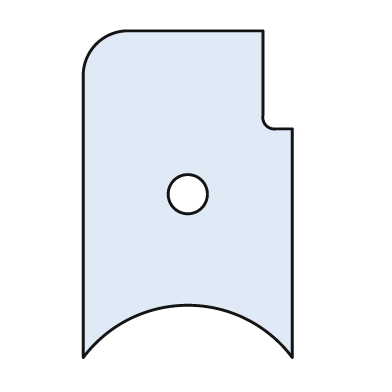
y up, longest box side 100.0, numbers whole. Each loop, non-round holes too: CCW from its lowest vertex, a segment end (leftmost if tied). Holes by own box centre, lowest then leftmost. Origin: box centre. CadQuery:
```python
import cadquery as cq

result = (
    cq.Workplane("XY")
    .moveTo(-32.0, -50.0)
    .threePointArc((0.0, -34.0), (32.0, -50.0))
    .lineTo(32.0, 20.0)
    .lineTo(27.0, 20.0)
    .threePointArc((24.0, 21.0), (23.0, 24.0))
    .lineTo(23.0, 50.0)
    .lineTo(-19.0, 50.0)
    .threePointArc((-28.0, 46.0), (-32.0, 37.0))
    .close()
    .moveTo(0.0, 0.0)
    .circle(6.0)
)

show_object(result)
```